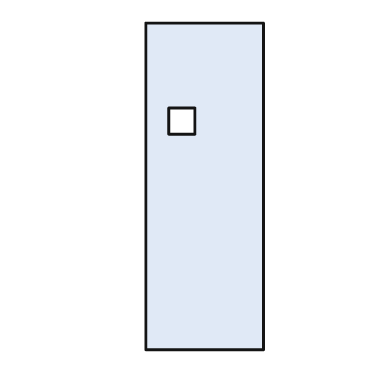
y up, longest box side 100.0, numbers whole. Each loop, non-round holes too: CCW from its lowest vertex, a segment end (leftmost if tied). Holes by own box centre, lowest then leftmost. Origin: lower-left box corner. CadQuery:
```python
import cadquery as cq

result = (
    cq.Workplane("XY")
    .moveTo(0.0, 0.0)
    .lineTo(36.0, 0.0)
    .lineTo(36.0, 100.0)
    .lineTo(0.0, 100.0)
    .close()
    .moveTo(7.0, 66.0)
    .lineTo(15.0, 66.0)
    .lineTo(15.0, 74.0)
    .lineTo(7.0, 74.0)
    .close()
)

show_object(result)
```